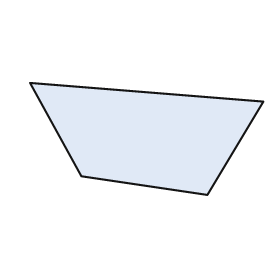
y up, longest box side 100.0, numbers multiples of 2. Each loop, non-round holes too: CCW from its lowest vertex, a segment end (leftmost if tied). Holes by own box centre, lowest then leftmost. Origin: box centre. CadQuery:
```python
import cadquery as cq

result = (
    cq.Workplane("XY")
    .moveTo(26.0, -24.0)
    .lineTo(50.0, 16.0)
    .lineTo(-50.0, 24.0)
    .lineTo(-28.0, -16.0)
    .close()
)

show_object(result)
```